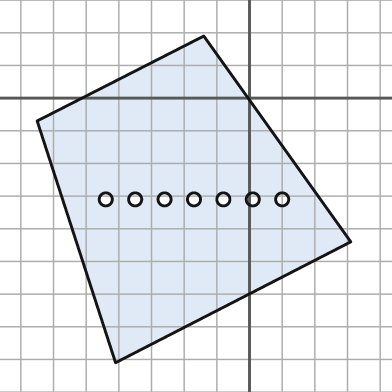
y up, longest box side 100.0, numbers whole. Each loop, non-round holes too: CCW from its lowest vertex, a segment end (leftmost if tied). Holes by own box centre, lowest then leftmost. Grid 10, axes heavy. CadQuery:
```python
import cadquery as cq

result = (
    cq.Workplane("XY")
    .moveTo(-41.0, -81.0)
    .lineTo(31.0, -44.0)
    .lineTo(-14.0, 19.0)
    .lineTo(-65.0, -7.0)
    .close()
    .moveTo(-44.0, -31.0)
    .circle(2.0)
    .moveTo(-35.0, -31.0)
    .circle(2.0)
    .moveTo(-26.0, -31.0)
    .circle(2.0)
    .moveTo(-17.0, -31.0)
    .circle(2.0)
    .moveTo(-8.0, -31.0)
    .circle(2.0)
    .moveTo(1.0, -31.0)
    .circle(2.0)
    .moveTo(10.0, -31.0)
    .circle(2.0)
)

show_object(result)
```